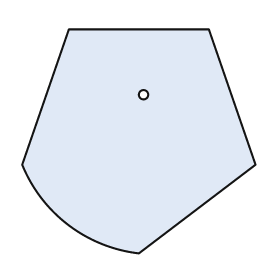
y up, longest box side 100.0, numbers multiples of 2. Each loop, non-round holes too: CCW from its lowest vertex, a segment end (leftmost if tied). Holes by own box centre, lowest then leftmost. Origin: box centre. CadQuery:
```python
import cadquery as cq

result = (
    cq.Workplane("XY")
    .moveTo(0.0, -48.0)
    .lineTo(50.0, -10.0)
    .lineTo(30.0, 48.0)
    .lineTo(-30.0, 48.0)
    .lineTo(-50.0, -10.0)
    .threePointArc((-30.0, -36.0), (0.0, -48.0))
    .close()
    .moveTo(2.0, 20.0)
    .circle(2.0)
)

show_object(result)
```